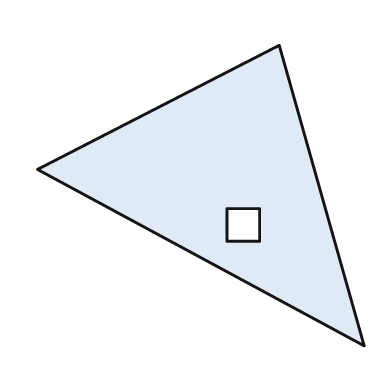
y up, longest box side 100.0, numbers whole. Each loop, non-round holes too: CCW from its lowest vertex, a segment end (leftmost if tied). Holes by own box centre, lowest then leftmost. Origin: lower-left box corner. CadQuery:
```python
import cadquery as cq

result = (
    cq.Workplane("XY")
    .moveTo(100.0, 0.0)
    .lineTo(74.0, 92.0)
    .lineTo(0.0, 54.0)
    .close()
    .moveTo(58.0, 32.0)
    .lineTo(68.0, 32.0)
    .lineTo(68.0, 42.0)
    .lineTo(58.0, 42.0)
    .close()
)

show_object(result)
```